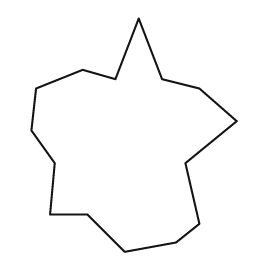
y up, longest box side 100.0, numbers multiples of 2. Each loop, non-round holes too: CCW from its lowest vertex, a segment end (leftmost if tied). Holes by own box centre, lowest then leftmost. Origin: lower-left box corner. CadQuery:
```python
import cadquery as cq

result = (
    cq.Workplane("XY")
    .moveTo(40.0, 0.0)
    .lineTo(62.0, 4.0)
    .lineTo(72.0, 12.0)
    .lineTo(66.0, 38.0)
    .lineTo(88.0, 56.0)
    .lineTo(72.0, 70.0)
    .lineTo(56.0, 74.0)
    .lineTo(46.0, 100.0)
    .lineTo(36.0, 74.0)
    .lineTo(22.0, 78.0)
    .lineTo(2.0, 70.0)
    .lineTo(0.0, 52.0)
    .lineTo(10.0, 38.0)
    .lineTo(8.0, 16.0)
    .lineTo(24.0, 16.0)
    .close()
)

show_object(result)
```